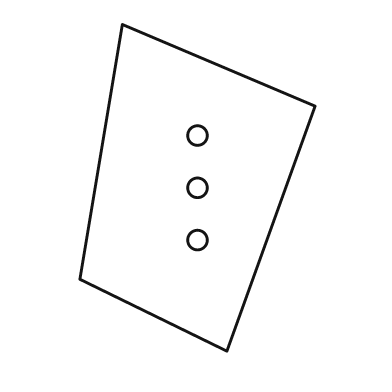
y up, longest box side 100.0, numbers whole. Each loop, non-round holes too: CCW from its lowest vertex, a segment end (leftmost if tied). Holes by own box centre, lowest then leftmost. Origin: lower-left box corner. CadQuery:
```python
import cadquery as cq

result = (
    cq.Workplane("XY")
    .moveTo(45.0, 0.0)
    .lineTo(72.0, 75.0)
    .lineTo(13.0, 100.0)
    .lineTo(0.0, 22.0)
    .close()
    .moveTo(36.0, 34.0)
    .circle(3.0)
    .moveTo(36.0, 50.0)
    .circle(3.0)
    .moveTo(36.0, 66.0)
    .circle(3.0)
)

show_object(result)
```